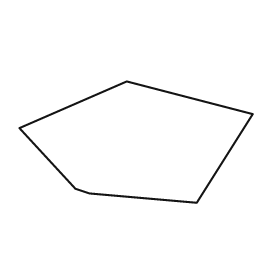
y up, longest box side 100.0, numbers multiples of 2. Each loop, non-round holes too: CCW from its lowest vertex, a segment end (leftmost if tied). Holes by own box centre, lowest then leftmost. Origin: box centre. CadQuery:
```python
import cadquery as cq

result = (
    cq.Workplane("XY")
    .moveTo(26.0, -26.0)
    .lineTo(50.0, 12.0)
    .lineTo(-4.0, 26.0)
    .lineTo(-50.0, 6.0)
    .lineTo(-26.0, -20.0)
    .lineTo(-20.0, -22.0)
    .close()
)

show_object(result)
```